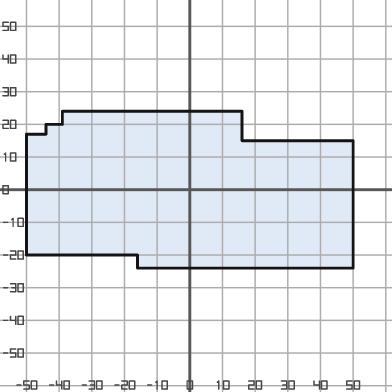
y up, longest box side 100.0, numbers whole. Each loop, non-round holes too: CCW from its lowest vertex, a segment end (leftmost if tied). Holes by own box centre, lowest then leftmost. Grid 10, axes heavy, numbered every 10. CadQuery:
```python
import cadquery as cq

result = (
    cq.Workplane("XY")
    .moveTo(-16.0, -24.0)
    .lineTo(50.0, -24.0)
    .lineTo(50.0, 15.0)
    .lineTo(16.0, 15.0)
    .lineTo(16.0, 24.0)
    .lineTo(-39.0, 24.0)
    .lineTo(-39.0, 20.0)
    .lineTo(-44.0, 20.0)
    .lineTo(-44.0, 17.0)
    .lineTo(-50.0, 17.0)
    .lineTo(-50.0, -20.0)
    .lineTo(-16.0, -20.0)
    .close()
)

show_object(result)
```